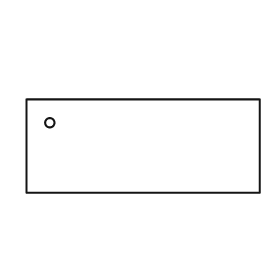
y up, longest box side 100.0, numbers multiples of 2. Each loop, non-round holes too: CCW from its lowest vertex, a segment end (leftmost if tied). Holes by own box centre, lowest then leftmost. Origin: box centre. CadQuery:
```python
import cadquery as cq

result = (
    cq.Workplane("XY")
    .moveTo(-50.0, -20.0)
    .lineTo(50.0, -20.0)
    .lineTo(50.0, 20.0)
    .lineTo(-50.0, 20.0)
    .close()
    .moveTo(-40.0, 10.0)
    .circle(2.0)
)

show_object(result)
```